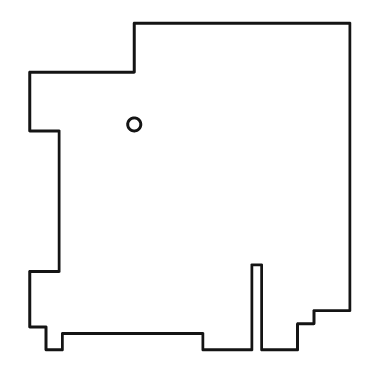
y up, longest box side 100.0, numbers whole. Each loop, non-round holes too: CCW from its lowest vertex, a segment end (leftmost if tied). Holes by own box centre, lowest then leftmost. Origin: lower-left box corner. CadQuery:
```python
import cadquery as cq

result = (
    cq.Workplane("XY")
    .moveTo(5.0, 0.0)
    .lineTo(10.0, 0.0)
    .lineTo(10.0, 5.0)
    .lineTo(53.0, 5.0)
    .lineTo(53.0, 0.0)
    .lineTo(68.0, 0.0)
    .lineTo(68.0, 26.0)
    .lineTo(71.0, 26.0)
    .lineTo(71.0, 0.0)
    .lineTo(82.0, 0.0)
    .lineTo(82.0, 8.0)
    .lineTo(87.0, 8.0)
    .lineTo(87.0, 12.0)
    .lineTo(98.0, 12.0)
    .lineTo(98.0, 100.0)
    .lineTo(32.0, 100.0)
    .lineTo(32.0, 85.0)
    .lineTo(0.0, 85.0)
    .lineTo(0.0, 67.0)
    .lineTo(9.0, 67.0)
    .lineTo(9.0, 24.0)
    .lineTo(0.0, 24.0)
    .lineTo(0.0, 7.0)
    .lineTo(5.0, 7.0)
    .close()
    .moveTo(32.0, 69.0)
    .circle(2.0)
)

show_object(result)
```